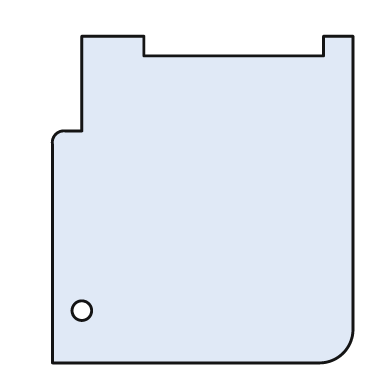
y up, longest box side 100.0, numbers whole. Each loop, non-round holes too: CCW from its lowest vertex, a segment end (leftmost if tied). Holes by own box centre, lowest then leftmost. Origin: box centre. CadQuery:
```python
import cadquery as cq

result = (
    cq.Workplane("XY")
    .moveTo(-46.0, -50.0)
    .lineTo(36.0, -50.0)
    .threePointArc((43.0, -47.0), (46.0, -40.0))
    .lineTo(46.0, 50.0)
    .lineTo(37.0, 50.0)
    .lineTo(37.0, 44.0)
    .lineTo(-18.0, 44.0)
    .lineTo(-18.0, 50.0)
    .lineTo(-37.0, 50.0)
    .lineTo(-37.0, 21.0)
    .lineTo(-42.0, 21.0)
    .threePointArc((-45.0, 20.0), (-46.0, 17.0))
    .close()
    .moveTo(-37.0, -34.0)
    .circle(3.0)
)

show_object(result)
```